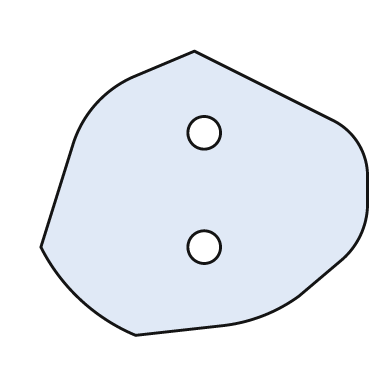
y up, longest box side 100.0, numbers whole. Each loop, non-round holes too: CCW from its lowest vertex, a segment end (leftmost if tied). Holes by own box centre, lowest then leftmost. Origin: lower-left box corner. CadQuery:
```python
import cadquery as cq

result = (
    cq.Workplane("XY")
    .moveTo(29.0, 0.0)
    .lineTo(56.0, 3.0)
    .threePointArc((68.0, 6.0), (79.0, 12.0))
    .lineTo(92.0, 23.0)
    .threePointArc((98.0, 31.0), (100.0, 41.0))
    .lineTo(100.0, 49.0)
    .threePointArc((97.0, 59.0), (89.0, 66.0))
    .lineTo(47.0, 87.0)
    .lineTo(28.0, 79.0)
    .threePointArc((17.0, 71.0), (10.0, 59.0))
    .lineTo(0.0, 27.0)
    .threePointArc((12.0, 11.0), (29.0, 0.0))
    .close()
    .moveTo(50.0, 27.0)
    .circle(5.0)
    .moveTo(50.0, 62.0)
    .circle(5.0)
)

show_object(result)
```